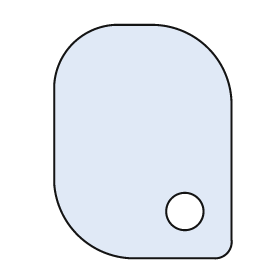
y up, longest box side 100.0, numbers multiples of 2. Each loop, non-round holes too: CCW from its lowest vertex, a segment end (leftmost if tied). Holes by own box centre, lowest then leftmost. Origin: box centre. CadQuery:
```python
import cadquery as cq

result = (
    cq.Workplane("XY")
    .moveTo(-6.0, -50.0)
    .lineTo(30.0, -50.0)
    .threePointArc((36.0, -48.0), (38.0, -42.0))
    .lineTo(38.0, 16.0)
    .threePointArc((28.0, 40.0), (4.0, 50.0))
    .lineTo(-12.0, 50.0)
    .threePointArc((-30.0, 42.0), (-38.0, 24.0))
    .lineTo(-38.0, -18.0)
    .threePointArc((-28.0, -40.0), (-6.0, -50.0))
    .close()
    .moveTo(18.0, -30.0)
    .circle(8.0)
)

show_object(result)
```